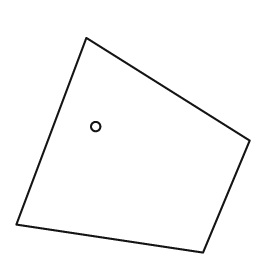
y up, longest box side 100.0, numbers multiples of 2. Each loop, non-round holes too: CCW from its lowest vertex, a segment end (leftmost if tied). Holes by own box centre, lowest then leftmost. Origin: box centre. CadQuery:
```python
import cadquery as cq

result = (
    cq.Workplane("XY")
    .moveTo(30.0, -46.0)
    .lineTo(50.0, 2.0)
    .lineTo(-20.0, 46.0)
    .lineTo(-50.0, -34.0)
    .close()
    .moveTo(-16.0, 8.0)
    .circle(2.0)
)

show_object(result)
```